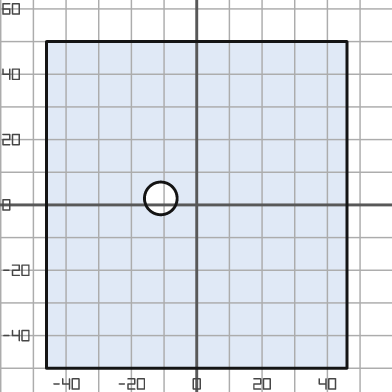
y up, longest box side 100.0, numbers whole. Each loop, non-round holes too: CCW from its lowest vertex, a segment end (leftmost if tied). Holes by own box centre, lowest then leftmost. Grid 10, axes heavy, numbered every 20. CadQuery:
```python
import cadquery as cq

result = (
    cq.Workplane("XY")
    .moveTo(-46.0, -50.0)
    .lineTo(46.0, -50.0)
    .lineTo(46.0, 50.0)
    .lineTo(-46.0, 50.0)
    .close()
    .moveTo(-11.0, 2.0)
    .circle(5.0)
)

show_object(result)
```